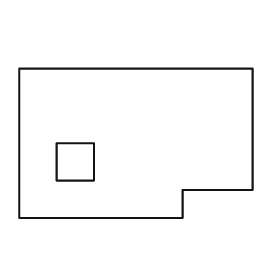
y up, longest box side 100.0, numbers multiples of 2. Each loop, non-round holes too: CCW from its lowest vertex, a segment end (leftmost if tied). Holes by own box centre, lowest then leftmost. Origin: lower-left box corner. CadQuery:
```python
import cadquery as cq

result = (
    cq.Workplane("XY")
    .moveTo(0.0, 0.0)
    .lineTo(70.0, 0.0)
    .lineTo(70.0, 12.0)
    .lineTo(100.0, 12.0)
    .lineTo(100.0, 64.0)
    .lineTo(0.0, 64.0)
    .close()
    .moveTo(16.0, 16.0)
    .lineTo(32.0, 16.0)
    .lineTo(32.0, 32.0)
    .lineTo(16.0, 32.0)
    .close()
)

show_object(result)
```